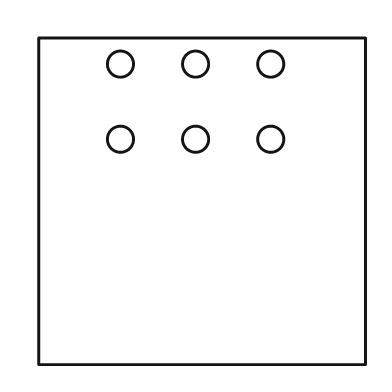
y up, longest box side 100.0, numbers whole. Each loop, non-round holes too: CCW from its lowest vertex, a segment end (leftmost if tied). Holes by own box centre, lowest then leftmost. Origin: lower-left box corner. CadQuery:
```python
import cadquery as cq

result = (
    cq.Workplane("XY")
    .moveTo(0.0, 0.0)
    .lineTo(100.0, 0.0)
    .lineTo(100.0, 100.0)
    .lineTo(0.0, 100.0)
    .close()
    .moveTo(25.0, 69.0)
    .circle(4.0)
    .moveTo(48.0, 69.0)
    .circle(4.0)
    .moveTo(71.0, 69.0)
    .circle(4.0)
    .moveTo(25.0, 92.0)
    .circle(4.0)
    .moveTo(48.0, 92.0)
    .circle(4.0)
    .moveTo(71.0, 92.0)
    .circle(4.0)
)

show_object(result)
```